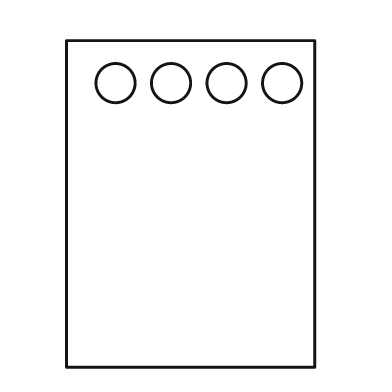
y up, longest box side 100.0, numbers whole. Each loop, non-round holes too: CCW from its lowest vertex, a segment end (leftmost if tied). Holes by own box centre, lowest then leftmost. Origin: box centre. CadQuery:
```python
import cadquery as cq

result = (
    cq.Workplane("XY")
    .moveTo(-38.0, -50.0)
    .lineTo(38.0, -50.0)
    .lineTo(38.0, 50.0)
    .lineTo(-38.0, 50.0)
    .close()
    .moveTo(-23.0, 37.0)
    .circle(6.0)
    .moveTo(-6.0, 37.0)
    .circle(6.0)
    .moveTo(11.0, 37.0)
    .circle(6.0)
    .moveTo(28.0, 37.0)
    .circle(6.0)
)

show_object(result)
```